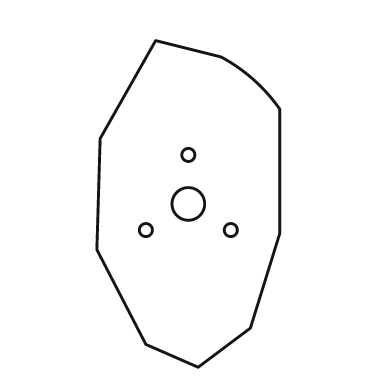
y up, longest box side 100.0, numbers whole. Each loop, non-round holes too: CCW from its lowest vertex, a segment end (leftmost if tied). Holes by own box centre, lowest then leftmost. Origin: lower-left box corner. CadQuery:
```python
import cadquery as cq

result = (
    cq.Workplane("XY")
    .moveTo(31.0, 0.0)
    .lineTo(47.0, 12.0)
    .lineTo(56.0, 41.0)
    .lineTo(56.0, 79.0)
    .threePointArc((48.0, 88.0), (38.0, 95.0))
    .lineTo(18.0, 100.0)
    .lineTo(1.0, 70.0)
    .lineTo(0.0, 36.0)
    .lineTo(15.0, 7.0)
    .close()
    .moveTo(15.0, 42.0)
    .circle(2.0)
    .moveTo(41.0, 42.0)
    .circle(2.0)
    .moveTo(28.0, 50.0)
    .circle(5.0)
    .moveTo(28.0, 65.0)
    .circle(2.0)
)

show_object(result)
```